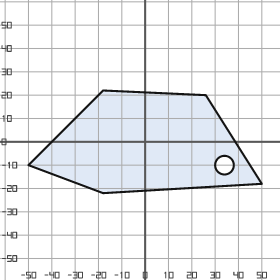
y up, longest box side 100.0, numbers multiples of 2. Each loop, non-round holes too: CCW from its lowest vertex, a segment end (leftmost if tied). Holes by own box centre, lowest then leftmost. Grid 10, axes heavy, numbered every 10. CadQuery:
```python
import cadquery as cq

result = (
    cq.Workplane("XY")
    .moveTo(-18.0, -22.0)
    .lineTo(50.0, -18.0)
    .lineTo(26.0, 20.0)
    .lineTo(-18.0, 22.0)
    .lineTo(-50.0, -10.0)
    .close()
    .moveTo(34.0, -10.0)
    .circle(4.0)
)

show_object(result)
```